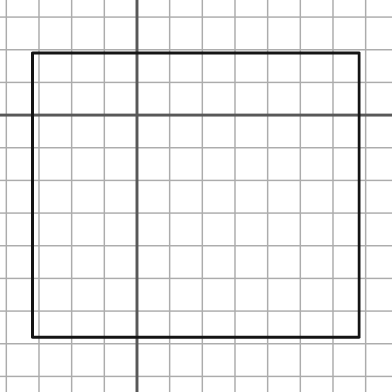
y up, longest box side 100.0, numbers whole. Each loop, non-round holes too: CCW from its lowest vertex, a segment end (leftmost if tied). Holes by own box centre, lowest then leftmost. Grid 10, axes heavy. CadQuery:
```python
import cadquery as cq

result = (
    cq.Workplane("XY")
    .moveTo(-32.0, -68.0)
    .lineTo(68.0, -68.0)
    .lineTo(68.0, 19.0)
    .lineTo(-32.0, 19.0)
    .close()
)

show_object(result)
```